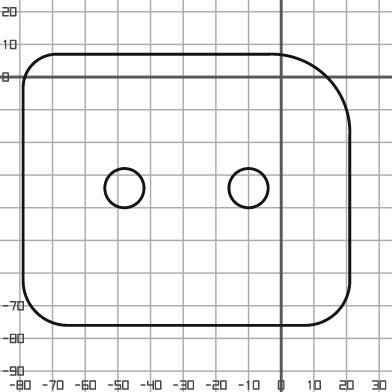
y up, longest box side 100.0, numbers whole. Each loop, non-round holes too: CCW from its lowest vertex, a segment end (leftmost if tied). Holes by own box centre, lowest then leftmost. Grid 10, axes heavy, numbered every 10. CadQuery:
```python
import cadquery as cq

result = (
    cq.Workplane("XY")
    .moveTo(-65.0, -76.0)
    .lineTo(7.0, -76.0)
    .threePointArc((17.0, -72.0), (21.0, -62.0))
    .lineTo(21.0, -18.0)
    .threePointArc((14.0, 0.0), (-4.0, 7.0))
    .lineTo(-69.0, 7.0)
    .threePointArc((-76.0, 4.0), (-79.0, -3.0))
    .lineTo(-79.0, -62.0)
    .threePointArc((-75.0, -72.0), (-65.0, -76.0))
    .close()
    .moveTo(-48.0, -34.0)
    .circle(6.0)
    .moveTo(-10.0, -34.0)
    .circle(6.0)
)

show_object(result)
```